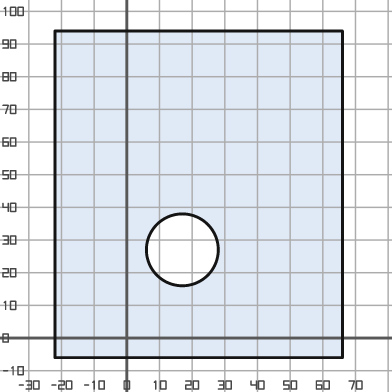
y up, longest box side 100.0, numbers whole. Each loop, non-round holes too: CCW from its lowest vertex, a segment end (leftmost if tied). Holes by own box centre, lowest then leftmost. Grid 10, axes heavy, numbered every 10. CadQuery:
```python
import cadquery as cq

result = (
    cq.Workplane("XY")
    .moveTo(-22.0, -6.0)
    .lineTo(66.0, -6.0)
    .lineTo(66.0, 94.0)
    .lineTo(-22.0, 94.0)
    .close()
    .moveTo(17.0, 27.0)
    .circle(11.0)
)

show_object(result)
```